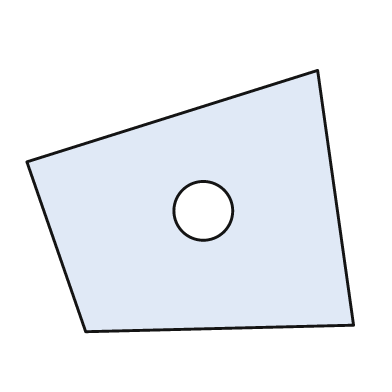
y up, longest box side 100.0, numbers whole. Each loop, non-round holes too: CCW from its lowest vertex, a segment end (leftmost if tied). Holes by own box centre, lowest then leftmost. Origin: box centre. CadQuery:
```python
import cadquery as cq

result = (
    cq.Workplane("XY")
    .moveTo(-32.0, -40.0)
    .lineTo(50.0, -38.0)
    .lineTo(39.0, 40.0)
    .lineTo(-50.0, 12.0)
    .close()
    .moveTo(4.0, -3.0)
    .circle(9.0)
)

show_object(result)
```